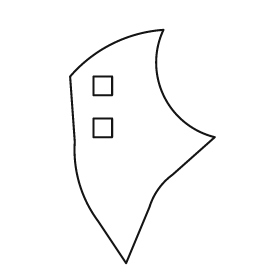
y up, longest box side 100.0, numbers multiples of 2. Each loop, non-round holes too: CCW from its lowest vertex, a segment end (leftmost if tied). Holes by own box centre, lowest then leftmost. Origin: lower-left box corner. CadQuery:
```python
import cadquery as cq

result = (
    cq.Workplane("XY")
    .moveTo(24.0, 0.0)
    .lineTo(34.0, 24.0)
    .threePointArc((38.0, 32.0), (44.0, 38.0))
    .lineTo(62.0, 54.0)
    .threePointArc((40.0, 72.0), (40.0, 100.0))
    .threePointArc((18.0, 94.0), (0.0, 80.0))
    .lineTo(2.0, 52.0)
    .threePointArc((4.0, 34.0), (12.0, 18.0))
    .close()
    .moveTo(10.0, 54.0)
    .lineTo(18.0, 54.0)
    .lineTo(18.0, 62.0)
    .lineTo(10.0, 62.0)
    .close()
    .moveTo(10.0, 72.0)
    .lineTo(18.0, 72.0)
    .lineTo(18.0, 80.0)
    .lineTo(10.0, 80.0)
    .close()
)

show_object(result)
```